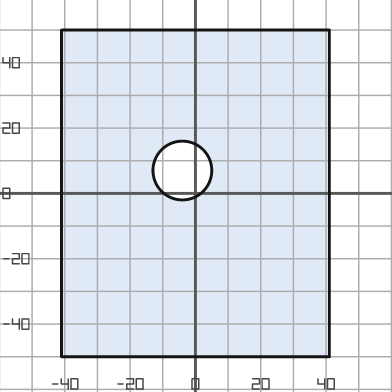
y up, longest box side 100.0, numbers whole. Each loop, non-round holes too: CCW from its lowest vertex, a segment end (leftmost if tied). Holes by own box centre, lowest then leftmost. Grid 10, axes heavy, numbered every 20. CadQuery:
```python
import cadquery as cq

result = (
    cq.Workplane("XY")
    .moveTo(-41.0, -50.0)
    .lineTo(41.0, -50.0)
    .lineTo(41.0, 50.0)
    .lineTo(-41.0, 50.0)
    .close()
    .moveTo(-4.0, 7.0)
    .circle(9.0)
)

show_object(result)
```